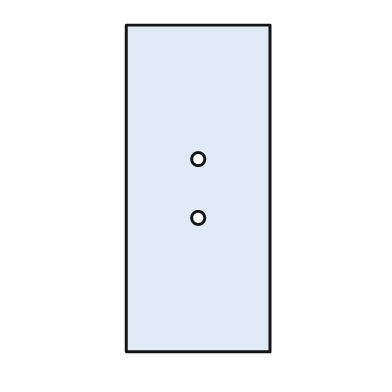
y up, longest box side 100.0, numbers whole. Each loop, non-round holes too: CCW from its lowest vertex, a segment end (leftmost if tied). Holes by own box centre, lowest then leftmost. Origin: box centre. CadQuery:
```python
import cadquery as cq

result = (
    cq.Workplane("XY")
    .moveTo(-22.0, -50.0)
    .lineTo(22.0, -50.0)
    .lineTo(22.0, 50.0)
    .lineTo(-22.0, 50.0)
    .close()
    .moveTo(0.0, -9.0)
    .circle(2.0)
    .moveTo(0.0, 9.0)
    .circle(2.0)
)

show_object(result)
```